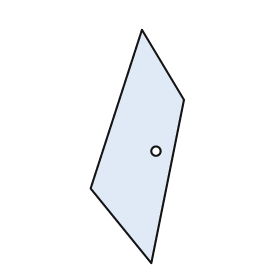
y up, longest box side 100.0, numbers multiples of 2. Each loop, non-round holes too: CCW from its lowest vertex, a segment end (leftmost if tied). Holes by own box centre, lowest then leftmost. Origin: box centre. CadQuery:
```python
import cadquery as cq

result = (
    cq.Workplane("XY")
    .moveTo(6.0, -50.0)
    .lineTo(20.0, 20.0)
    .lineTo(2.0, 50.0)
    .lineTo(-20.0, -18.0)
    .close()
    .moveTo(8.0, -2.0)
    .circle(2.0)
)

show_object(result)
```